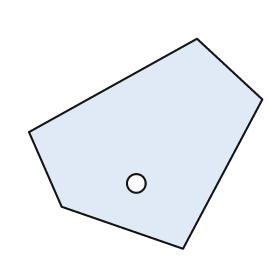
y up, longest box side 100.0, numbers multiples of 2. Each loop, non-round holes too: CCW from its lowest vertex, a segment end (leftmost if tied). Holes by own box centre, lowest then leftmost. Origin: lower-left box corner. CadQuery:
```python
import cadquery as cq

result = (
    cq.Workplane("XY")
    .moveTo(66.0, 0.0)
    .lineTo(100.0, 64.0)
    .lineTo(72.0, 90.0)
    .lineTo(0.0, 50.0)
    .lineTo(14.0, 18.0)
    .close()
    .moveTo(46.0, 28.0)
    .circle(4.0)
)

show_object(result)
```